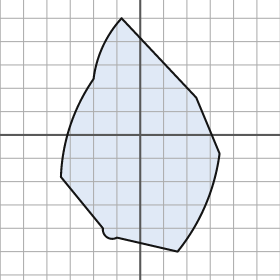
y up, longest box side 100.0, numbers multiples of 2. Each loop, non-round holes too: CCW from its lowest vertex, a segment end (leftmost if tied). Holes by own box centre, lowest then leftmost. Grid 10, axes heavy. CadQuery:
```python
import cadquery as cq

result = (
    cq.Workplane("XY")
    .moveTo(16.0, -50.0)
    .threePointArc((28.0, -30.0), (34.0, -8.0))
    .lineTo(24.0, 16.0)
    .lineTo(-8.0, 50.0)
    .threePointArc((-16.0, 38.0), (-20.0, 24.0))
    .threePointArc((-30.0, 4.0), (-34.0, -18.0))
    .lineTo(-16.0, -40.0)
    .threePointArc((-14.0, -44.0), (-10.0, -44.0))
    .close()
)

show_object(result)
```